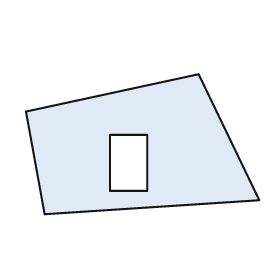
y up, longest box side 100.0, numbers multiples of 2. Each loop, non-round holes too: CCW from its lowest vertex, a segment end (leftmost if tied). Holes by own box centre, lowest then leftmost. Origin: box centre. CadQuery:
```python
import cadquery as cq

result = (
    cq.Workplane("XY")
    .moveTo(-42.0, -30.0)
    .lineTo(50.0, -24.0)
    .lineTo(24.0, 30.0)
    .lineTo(-50.0, 14.0)
    .close()
    .moveTo(-14.0, -20.0)
    .lineTo(2.0, -20.0)
    .lineTo(2.0, 4.0)
    .lineTo(-14.0, 4.0)
    .close()
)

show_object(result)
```